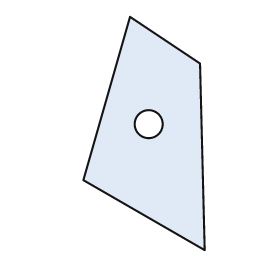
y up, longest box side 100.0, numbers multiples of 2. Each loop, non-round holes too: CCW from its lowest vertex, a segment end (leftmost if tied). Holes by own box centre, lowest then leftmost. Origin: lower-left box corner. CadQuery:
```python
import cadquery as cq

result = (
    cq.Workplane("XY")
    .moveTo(52.0, 0.0)
    .lineTo(50.0, 80.0)
    .lineTo(20.0, 100.0)
    .lineTo(0.0, 30.0)
    .close()
    .moveTo(28.0, 54.0)
    .circle(6.0)
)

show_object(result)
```